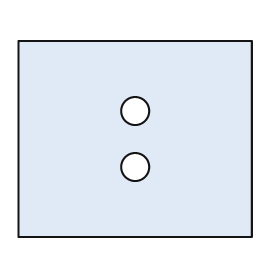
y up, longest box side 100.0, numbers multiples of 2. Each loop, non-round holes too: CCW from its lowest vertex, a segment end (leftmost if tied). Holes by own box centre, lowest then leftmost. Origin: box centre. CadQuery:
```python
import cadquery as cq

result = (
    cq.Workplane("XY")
    .moveTo(-50.0, -42.0)
    .lineTo(50.0, -42.0)
    .lineTo(50.0, 42.0)
    .lineTo(-50.0, 42.0)
    .close()
    .moveTo(0.0, -12.0)
    .circle(6.0)
    .moveTo(0.0, 12.0)
    .circle(6.0)
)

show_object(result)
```